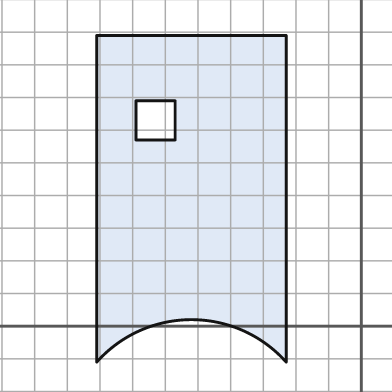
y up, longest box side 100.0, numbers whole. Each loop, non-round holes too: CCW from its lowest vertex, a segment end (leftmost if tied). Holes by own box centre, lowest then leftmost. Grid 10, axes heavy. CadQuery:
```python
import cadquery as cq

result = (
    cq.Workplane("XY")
    .moveTo(-81.0, -11.0)
    .threePointArc((-52.0, 2.0), (-23.0, -11.0))
    .lineTo(-23.0, 89.0)
    .lineTo(-81.0, 89.0)
    .close()
    .moveTo(-69.0, 57.0)
    .lineTo(-57.0, 57.0)
    .lineTo(-57.0, 69.0)
    .lineTo(-69.0, 69.0)
    .close()
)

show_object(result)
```